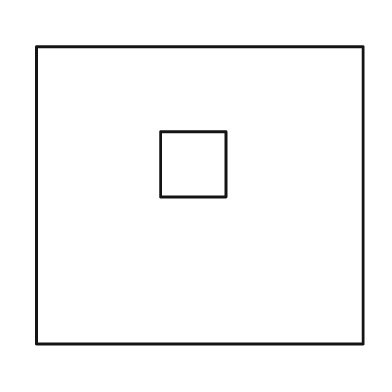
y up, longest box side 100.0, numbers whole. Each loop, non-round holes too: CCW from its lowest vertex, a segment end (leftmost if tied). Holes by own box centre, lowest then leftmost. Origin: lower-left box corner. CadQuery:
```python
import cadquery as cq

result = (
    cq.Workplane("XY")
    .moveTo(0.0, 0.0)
    .lineTo(100.0, 0.0)
    .lineTo(100.0, 91.0)
    .lineTo(0.0, 91.0)
    .close()
    .moveTo(38.0, 45.0)
    .lineTo(58.0, 45.0)
    .lineTo(58.0, 65.0)
    .lineTo(38.0, 65.0)
    .close()
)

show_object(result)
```